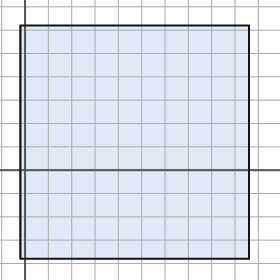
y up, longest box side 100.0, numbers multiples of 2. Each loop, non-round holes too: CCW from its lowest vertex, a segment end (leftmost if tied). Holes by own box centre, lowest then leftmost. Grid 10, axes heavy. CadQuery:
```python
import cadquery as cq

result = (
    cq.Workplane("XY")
    .moveTo(-2.0, -38.0)
    .lineTo(96.0, -38.0)
    .lineTo(96.0, 62.0)
    .lineTo(-2.0, 62.0)
    .close()
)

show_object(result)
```